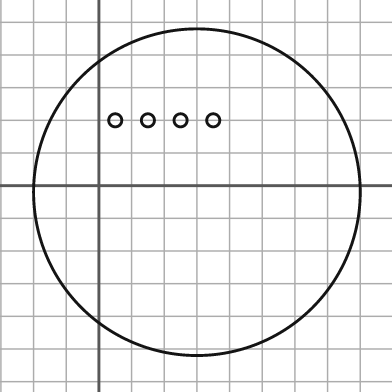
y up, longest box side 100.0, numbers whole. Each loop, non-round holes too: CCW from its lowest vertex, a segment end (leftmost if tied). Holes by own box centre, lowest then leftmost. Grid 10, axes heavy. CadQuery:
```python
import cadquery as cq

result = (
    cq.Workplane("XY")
    .moveTo(30.0, -2.0)
    .circle(50.0)
    .moveTo(5.0, 20.0)
    .circle(2.0)
    .moveTo(15.0, 20.0)
    .circle(2.0)
    .moveTo(25.0, 20.0)
    .circle(2.0)
    .moveTo(35.0, 20.0)
    .circle(2.0)
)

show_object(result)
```